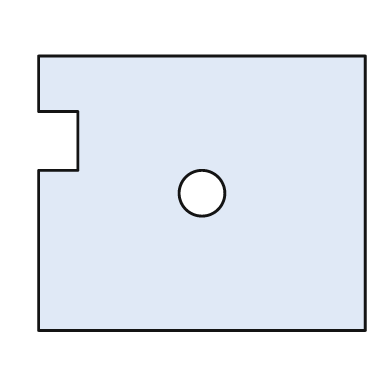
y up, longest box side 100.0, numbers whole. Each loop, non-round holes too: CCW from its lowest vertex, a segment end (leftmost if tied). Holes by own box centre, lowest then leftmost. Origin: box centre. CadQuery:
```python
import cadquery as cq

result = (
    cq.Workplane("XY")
    .moveTo(-50.0, -42.0)
    .lineTo(50.0, -42.0)
    .lineTo(50.0, 42.0)
    .lineTo(-50.0, 42.0)
    .lineTo(-50.0, 25.0)
    .lineTo(-38.0, 25.0)
    .lineTo(-38.0, 7.0)
    .lineTo(-50.0, 7.0)
    .close()
    .moveTo(0.0, 0.0)
    .circle(7.0)
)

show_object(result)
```